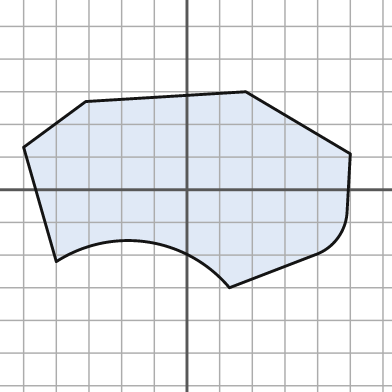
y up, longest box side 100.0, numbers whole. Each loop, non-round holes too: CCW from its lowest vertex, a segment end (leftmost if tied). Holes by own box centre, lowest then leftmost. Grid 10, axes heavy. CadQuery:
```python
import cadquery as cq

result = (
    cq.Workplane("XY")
    .moveTo(13.0, -30.0)
    .lineTo(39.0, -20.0)
    .threePointArc((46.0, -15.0), (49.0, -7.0))
    .lineTo(50.0, 11.0)
    .lineTo(18.0, 30.0)
    .lineTo(-31.0, 27.0)
    .lineTo(-50.0, 13.0)
    .lineTo(-40.0, -22.0)
    .threePointArc((-12.0, -16.0), (13.0, -30.0))
    .close()
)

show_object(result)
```